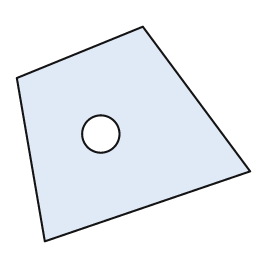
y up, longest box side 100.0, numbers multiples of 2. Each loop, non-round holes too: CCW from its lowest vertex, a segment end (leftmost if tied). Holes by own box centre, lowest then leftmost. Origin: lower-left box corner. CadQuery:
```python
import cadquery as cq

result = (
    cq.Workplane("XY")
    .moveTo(12.0, 0.0)
    .lineTo(100.0, 30.0)
    .lineTo(54.0, 92.0)
    .lineTo(0.0, 70.0)
    .close()
    .moveTo(36.0, 46.0)
    .circle(8.0)
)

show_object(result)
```